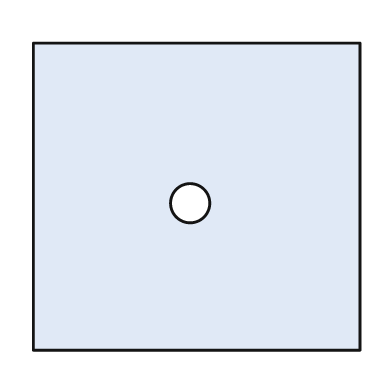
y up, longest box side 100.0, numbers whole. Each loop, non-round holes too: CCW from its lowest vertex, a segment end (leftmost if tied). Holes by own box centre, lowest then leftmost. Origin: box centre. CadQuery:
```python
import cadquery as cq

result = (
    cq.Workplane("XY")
    .moveTo(-50.0, -47.0)
    .lineTo(50.0, -47.0)
    .lineTo(50.0, 47.0)
    .lineTo(-50.0, 47.0)
    .close()
    .moveTo(-2.0, -2.0)
    .circle(6.0)
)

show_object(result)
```